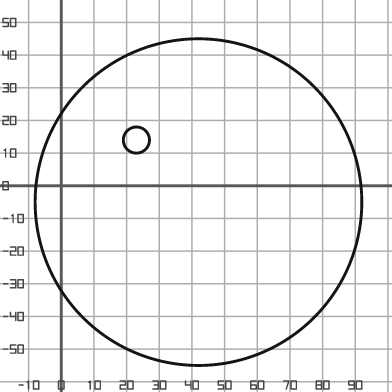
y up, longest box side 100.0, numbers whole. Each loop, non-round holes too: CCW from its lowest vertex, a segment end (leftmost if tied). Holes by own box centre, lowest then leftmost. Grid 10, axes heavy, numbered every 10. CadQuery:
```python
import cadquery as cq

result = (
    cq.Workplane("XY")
    .moveTo(42.0, -5.0)
    .circle(50.0)
    .moveTo(23.0, 14.0)
    .circle(4.0)
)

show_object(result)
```